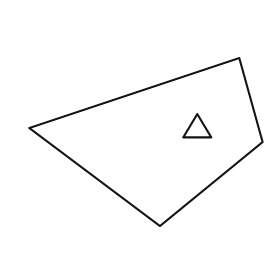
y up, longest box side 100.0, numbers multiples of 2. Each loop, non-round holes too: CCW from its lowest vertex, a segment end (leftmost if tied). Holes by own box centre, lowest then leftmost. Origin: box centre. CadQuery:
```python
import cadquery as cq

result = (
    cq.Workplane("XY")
    .moveTo(6.0, -36.0)
    .lineTo(50.0, 0.0)
    .lineTo(40.0, 36.0)
    .lineTo(-50.0, 6.0)
    .close()
    .moveTo(16.0, 2.0)
    .lineTo(28.0, 2.0)
    .lineTo(22.0, 12.0)
    .close()
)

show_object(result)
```